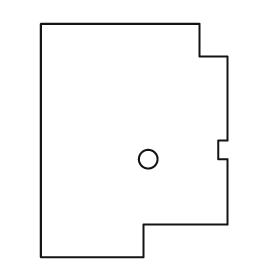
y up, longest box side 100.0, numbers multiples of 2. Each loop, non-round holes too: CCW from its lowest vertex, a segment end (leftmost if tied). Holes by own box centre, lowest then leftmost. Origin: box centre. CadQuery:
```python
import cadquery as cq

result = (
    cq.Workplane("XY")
    .moveTo(-40.0, -50.0)
    .lineTo(4.0, -50.0)
    .lineTo(4.0, -36.0)
    .lineTo(40.0, -36.0)
    .lineTo(40.0, -8.0)
    .lineTo(36.0, -8.0)
    .lineTo(36.0, 0.0)
    .lineTo(40.0, 0.0)
    .lineTo(40.0, 36.0)
    .lineTo(28.0, 36.0)
    .lineTo(28.0, 50.0)
    .lineTo(-40.0, 50.0)
    .close()
    .moveTo(6.0, -8.0)
    .circle(4.0)
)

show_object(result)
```